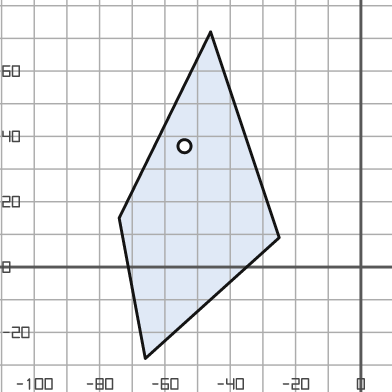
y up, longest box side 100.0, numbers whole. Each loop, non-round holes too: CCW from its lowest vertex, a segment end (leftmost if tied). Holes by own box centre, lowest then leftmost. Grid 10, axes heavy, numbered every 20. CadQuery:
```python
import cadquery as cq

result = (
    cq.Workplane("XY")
    .moveTo(-66.0, -28.0)
    .lineTo(-25.0, 9.0)
    .lineTo(-46.0, 72.0)
    .lineTo(-74.0, 15.0)
    .close()
    .moveTo(-54.0, 37.0)
    .circle(2.0)
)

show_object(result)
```